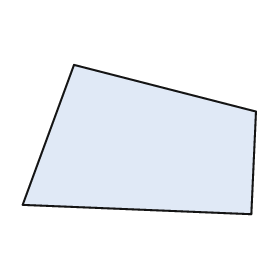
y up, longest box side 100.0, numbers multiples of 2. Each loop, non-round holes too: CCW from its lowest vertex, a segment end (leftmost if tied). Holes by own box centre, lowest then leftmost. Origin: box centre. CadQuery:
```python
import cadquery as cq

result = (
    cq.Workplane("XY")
    .moveTo(48.0, -32.0)
    .lineTo(50.0, 12.0)
    .lineTo(-28.0, 32.0)
    .lineTo(-50.0, -28.0)
    .close()
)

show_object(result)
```